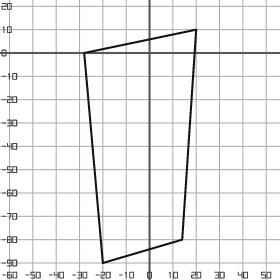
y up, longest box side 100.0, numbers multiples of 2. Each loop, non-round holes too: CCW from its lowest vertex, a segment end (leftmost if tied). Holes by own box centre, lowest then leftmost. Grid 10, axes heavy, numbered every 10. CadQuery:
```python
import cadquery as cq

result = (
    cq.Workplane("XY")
    .moveTo(-20.0, -90.0)
    .lineTo(14.0, -80.0)
    .lineTo(20.0, 10.0)
    .lineTo(-28.0, 0.0)
    .close()
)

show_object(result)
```